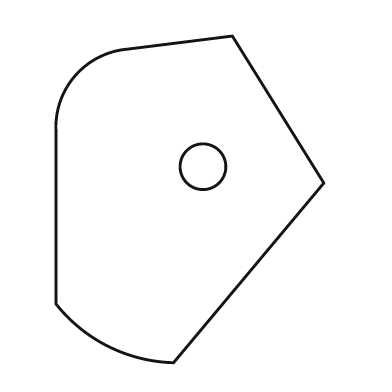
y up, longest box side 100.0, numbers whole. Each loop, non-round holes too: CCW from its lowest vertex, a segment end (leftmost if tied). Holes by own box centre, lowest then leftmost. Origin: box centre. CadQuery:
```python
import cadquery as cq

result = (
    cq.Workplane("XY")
    .moveTo(-5.0, -50.0)
    .lineTo(41.0, 5.0)
    .lineTo(13.0, 50.0)
    .lineTo(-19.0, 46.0)
    .threePointArc((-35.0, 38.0), (-41.0, 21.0))
    .lineTo(-41.0, -32.0)
    .threePointArc((-25.0, -45.0), (-5.0, -50.0))
    .close()
    .moveTo(4.0, 10.0)
    .circle(7.0)
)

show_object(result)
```